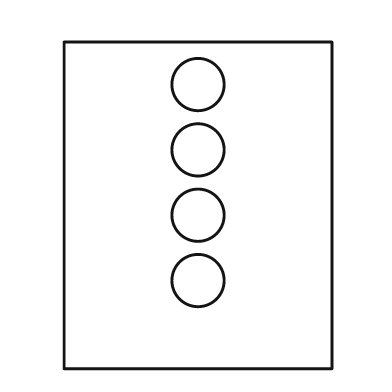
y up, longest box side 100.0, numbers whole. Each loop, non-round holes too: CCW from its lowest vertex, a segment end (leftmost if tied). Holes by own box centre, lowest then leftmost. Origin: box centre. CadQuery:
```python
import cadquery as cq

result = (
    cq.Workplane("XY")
    .moveTo(-41.0, -50.0)
    .lineTo(41.0, -50.0)
    .lineTo(41.0, 50.0)
    .lineTo(-41.0, 50.0)
    .close()
    .moveTo(0.0, -23.0)
    .circle(8.0)
    .moveTo(0.0, -3.0)
    .circle(8.0)
    .moveTo(0.0, 17.0)
    .circle(8.0)
    .moveTo(0.0, 37.0)
    .circle(8.0)
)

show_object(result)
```